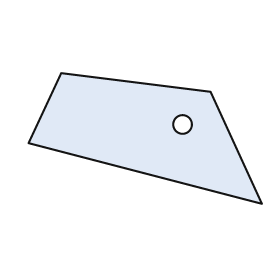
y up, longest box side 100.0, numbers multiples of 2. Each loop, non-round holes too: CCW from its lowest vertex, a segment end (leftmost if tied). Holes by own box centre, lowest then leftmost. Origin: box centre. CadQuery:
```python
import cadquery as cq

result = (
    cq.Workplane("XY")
    .moveTo(50.0, -28.0)
    .lineTo(28.0, 20.0)
    .lineTo(-36.0, 28.0)
    .lineTo(-50.0, -2.0)
    .close()
    .moveTo(16.0, 6.0)
    .circle(4.0)
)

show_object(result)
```